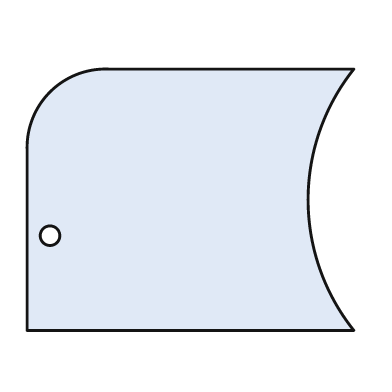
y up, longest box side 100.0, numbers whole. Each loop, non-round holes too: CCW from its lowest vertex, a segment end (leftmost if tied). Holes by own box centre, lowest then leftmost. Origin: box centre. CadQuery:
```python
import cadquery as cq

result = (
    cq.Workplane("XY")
    .moveTo(-50.0, -40.0)
    .lineTo(50.0, -40.0)
    .threePointArc((36.0, 0.0), (50.0, 40.0))
    .lineTo(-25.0, 40.0)
    .threePointArc((-43.0, 33.0), (-50.0, 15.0))
    .close()
    .moveTo(-43.0, -11.0)
    .circle(3.0)
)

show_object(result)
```